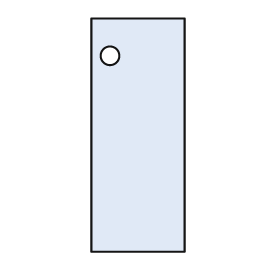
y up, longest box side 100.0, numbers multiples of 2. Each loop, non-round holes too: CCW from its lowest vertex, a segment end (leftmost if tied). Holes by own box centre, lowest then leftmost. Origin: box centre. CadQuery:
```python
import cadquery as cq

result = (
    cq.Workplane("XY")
    .moveTo(-20.0, -50.0)
    .lineTo(20.0, -50.0)
    .lineTo(20.0, 50.0)
    .lineTo(-20.0, 50.0)
    .close()
    .moveTo(-12.0, 34.0)
    .circle(4.0)
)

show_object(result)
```